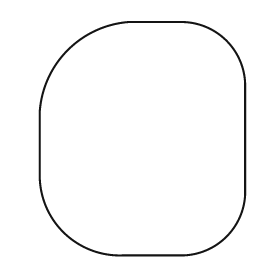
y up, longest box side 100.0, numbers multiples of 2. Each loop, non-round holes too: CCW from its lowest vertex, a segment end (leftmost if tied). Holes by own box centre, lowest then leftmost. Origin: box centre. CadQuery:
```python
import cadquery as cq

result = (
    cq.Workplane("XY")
    .moveTo(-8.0, -50.0)
    .lineTo(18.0, -50.0)
    .threePointArc((36.0, -42.0), (44.0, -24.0))
    .lineTo(44.0, 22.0)
    .threePointArc((36.0, 42.0), (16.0, 50.0))
    .lineTo(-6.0, 50.0)
    .threePointArc((-32.0, 38.0), (-44.0, 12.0))
    .lineTo(-44.0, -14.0)
    .threePointArc((-34.0, -40.0), (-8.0, -50.0))
    .close()
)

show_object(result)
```